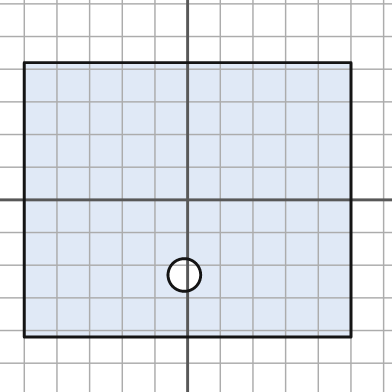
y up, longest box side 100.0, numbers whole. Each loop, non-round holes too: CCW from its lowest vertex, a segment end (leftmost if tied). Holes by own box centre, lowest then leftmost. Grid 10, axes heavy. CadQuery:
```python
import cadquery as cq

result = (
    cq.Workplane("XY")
    .moveTo(-50.0, -42.0)
    .lineTo(50.0, -42.0)
    .lineTo(50.0, 42.0)
    .lineTo(-50.0, 42.0)
    .close()
    .moveTo(-1.0, -23.0)
    .circle(5.0)
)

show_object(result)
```